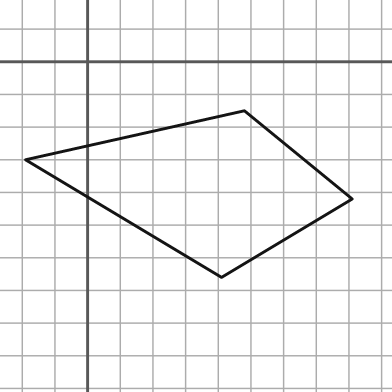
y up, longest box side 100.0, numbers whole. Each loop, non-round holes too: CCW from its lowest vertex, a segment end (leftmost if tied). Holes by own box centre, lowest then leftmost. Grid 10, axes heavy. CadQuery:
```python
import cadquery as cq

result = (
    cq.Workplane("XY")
    .moveTo(41.0, -66.0)
    .lineTo(81.0, -42.0)
    .lineTo(48.0, -15.0)
    .lineTo(-19.0, -30.0)
    .close()
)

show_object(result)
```